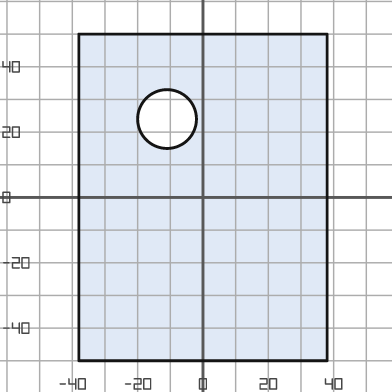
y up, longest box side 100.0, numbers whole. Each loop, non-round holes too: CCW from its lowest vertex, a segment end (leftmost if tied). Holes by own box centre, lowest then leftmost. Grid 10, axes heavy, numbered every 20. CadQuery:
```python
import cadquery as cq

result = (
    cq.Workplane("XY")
    .moveTo(-38.0, -50.0)
    .lineTo(38.0, -50.0)
    .lineTo(38.0, 50.0)
    .lineTo(-38.0, 50.0)
    .close()
    .moveTo(-11.0, 24.0)
    .circle(9.0)
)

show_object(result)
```